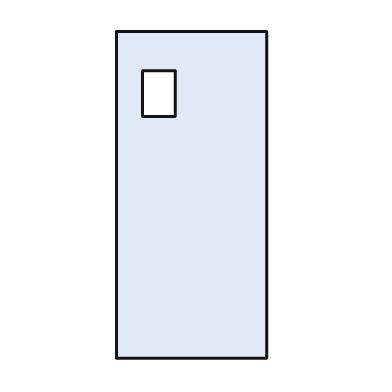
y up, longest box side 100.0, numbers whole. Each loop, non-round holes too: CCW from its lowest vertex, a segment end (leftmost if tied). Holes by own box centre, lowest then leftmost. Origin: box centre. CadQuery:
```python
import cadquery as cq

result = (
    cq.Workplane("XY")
    .moveTo(-23.0, -50.0)
    .lineTo(23.0, -50.0)
    .lineTo(23.0, 50.0)
    .lineTo(-23.0, 50.0)
    .close()
    .moveTo(-15.0, 24.0)
    .lineTo(-5.0, 24.0)
    .lineTo(-5.0, 38.0)
    .lineTo(-15.0, 38.0)
    .close()
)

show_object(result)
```